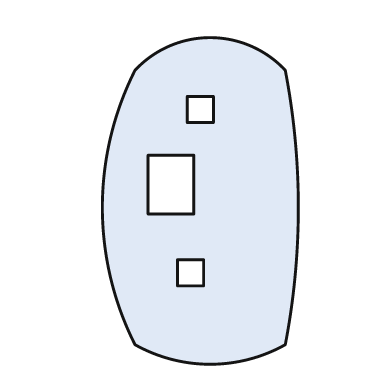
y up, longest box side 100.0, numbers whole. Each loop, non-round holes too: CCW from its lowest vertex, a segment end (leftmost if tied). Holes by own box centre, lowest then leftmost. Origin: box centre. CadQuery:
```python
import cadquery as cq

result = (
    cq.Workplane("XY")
    .moveTo(-20.0, -44.0)
    .threePointArc((3.0, -50.0), (26.0, -44.0))
    .threePointArc((30.0, -2.0), (26.0, 40.0))
    .threePointArc((3.0, 50.0), (-20.0, 40.0))
    .threePointArc((-30.0, -2.0), (-20.0, -44.0))
    .close()
    .moveTo(-7.0, -26.0)
    .lineTo(1.0, -26.0)
    .lineTo(1.0, -18.0)
    .lineTo(-7.0, -18.0)
    .close()
    .moveTo(-16.0, -4.0)
    .lineTo(-2.0, -4.0)
    .lineTo(-2.0, 14.0)
    .lineTo(-16.0, 14.0)
    .close()
    .moveTo(-4.0, 24.0)
    .lineTo(4.0, 24.0)
    .lineTo(4.0, 32.0)
    .lineTo(-4.0, 32.0)
    .close()
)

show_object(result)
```